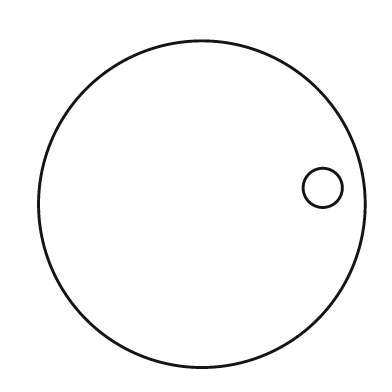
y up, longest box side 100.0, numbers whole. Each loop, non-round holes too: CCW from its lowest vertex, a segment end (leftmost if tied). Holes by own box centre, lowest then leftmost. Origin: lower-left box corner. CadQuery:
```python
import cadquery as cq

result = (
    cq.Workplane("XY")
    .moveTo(50.0, 50.0)
    .circle(50.0)
    .moveTo(87.0, 55.0)
    .circle(6.0)
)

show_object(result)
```